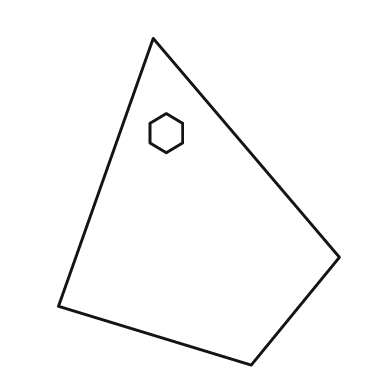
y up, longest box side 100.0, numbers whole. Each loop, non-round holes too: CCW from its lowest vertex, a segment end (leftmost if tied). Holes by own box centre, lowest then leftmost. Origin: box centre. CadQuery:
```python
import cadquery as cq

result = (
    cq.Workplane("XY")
    .moveTo(16.0, -50.0)
    .lineTo(43.0, -17.0)
    .lineTo(-14.0, 50.0)
    .lineTo(-43.0, -32.0)
    .close()
    .moveTo(-10.0, 15.0)
    .lineTo(-5.0, 18.0)
    .lineTo(-5.0, 24.0)
    .lineTo(-10.0, 27.0)
    .lineTo(-15.0, 24.0)
    .lineTo(-15.0, 18.0)
    .close()
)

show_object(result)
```